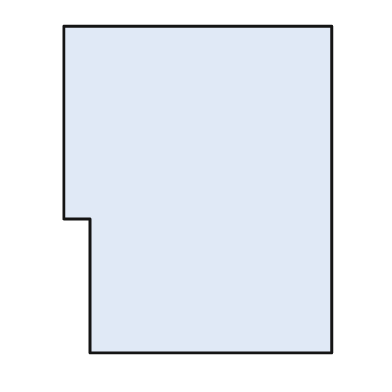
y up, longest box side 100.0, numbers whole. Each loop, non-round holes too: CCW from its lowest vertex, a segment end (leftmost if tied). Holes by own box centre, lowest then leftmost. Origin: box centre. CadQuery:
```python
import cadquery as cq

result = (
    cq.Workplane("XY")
    .moveTo(-33.0, -50.0)
    .lineTo(41.0, -50.0)
    .lineTo(41.0, 50.0)
    .lineTo(-41.0, 50.0)
    .lineTo(-41.0, -9.0)
    .lineTo(-33.0, -9.0)
    .close()
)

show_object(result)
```